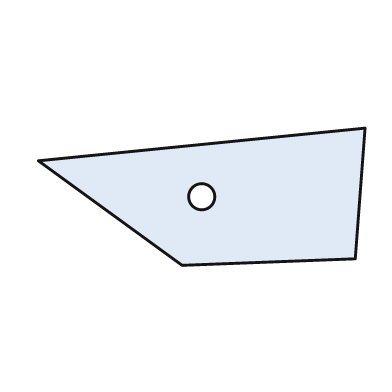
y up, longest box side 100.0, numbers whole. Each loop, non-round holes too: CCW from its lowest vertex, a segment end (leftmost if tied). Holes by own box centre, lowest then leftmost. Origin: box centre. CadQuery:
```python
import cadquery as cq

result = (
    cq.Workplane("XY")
    .moveTo(-6.0, -21.0)
    .lineTo(47.0, -19.0)
    .lineTo(50.0, 21.0)
    .lineTo(-50.0, 11.0)
    .close()
    .moveTo(0.0, 0.0)
    .circle(4.0)
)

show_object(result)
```